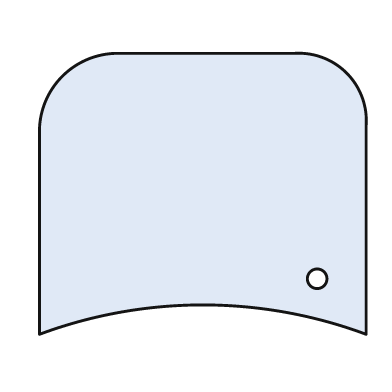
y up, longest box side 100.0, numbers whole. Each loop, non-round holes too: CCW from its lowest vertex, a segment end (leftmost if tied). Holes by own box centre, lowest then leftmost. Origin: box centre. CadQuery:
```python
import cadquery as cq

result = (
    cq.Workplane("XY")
    .moveTo(-50.0, -43.0)
    .threePointArc((0.0, -34.0), (50.0, -43.0))
    .lineTo(50.0, 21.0)
    .threePointArc((44.0, 37.0), (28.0, 43.0))
    .lineTo(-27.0, 43.0)
    .threePointArc((-43.0, 36.0), (-50.0, 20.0))
    .close()
    .moveTo(35.0, -26.0)
    .circle(3.0)
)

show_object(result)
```